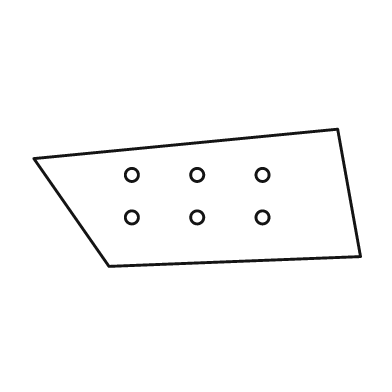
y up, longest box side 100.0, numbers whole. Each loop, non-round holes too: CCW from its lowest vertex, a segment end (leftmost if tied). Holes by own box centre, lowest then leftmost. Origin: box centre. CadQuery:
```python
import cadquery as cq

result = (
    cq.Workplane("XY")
    .moveTo(-27.0, -21.0)
    .lineTo(50.0, -18.0)
    .lineTo(43.0, 21.0)
    .lineTo(-50.0, 12.0)
    .close()
    .moveTo(-20.0, -6.0)
    .circle(2.0)
    .moveTo(0.0, -6.0)
    .circle(2.0)
    .moveTo(20.0, -6.0)
    .circle(2.0)
    .moveTo(-20.0, 7.0)
    .circle(2.0)
    .moveTo(0.0, 7.0)
    .circle(2.0)
    .moveTo(20.0, 7.0)
    .circle(2.0)
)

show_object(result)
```